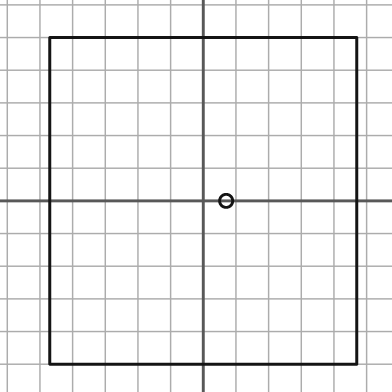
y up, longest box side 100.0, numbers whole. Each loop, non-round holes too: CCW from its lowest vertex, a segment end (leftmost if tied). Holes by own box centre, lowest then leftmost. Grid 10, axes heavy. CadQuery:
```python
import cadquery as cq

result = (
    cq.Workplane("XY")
    .moveTo(-47.0, -50.0)
    .lineTo(47.0, -50.0)
    .lineTo(47.0, 50.0)
    .lineTo(-47.0, 50.0)
    .close()
    .moveTo(7.0, 0.0)
    .circle(2.0)
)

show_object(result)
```